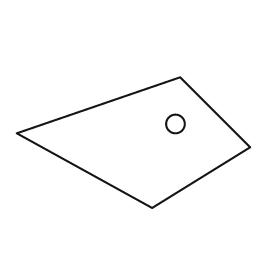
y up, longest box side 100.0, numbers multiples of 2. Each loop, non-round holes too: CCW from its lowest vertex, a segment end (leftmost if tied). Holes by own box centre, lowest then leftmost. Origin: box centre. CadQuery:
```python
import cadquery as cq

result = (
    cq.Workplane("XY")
    .moveTo(8.0, -28.0)
    .lineTo(50.0, -2.0)
    .lineTo(20.0, 28.0)
    .lineTo(-50.0, 4.0)
    .close()
    .moveTo(18.0, 8.0)
    .circle(4.0)
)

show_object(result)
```